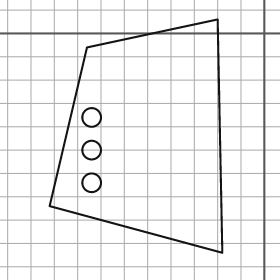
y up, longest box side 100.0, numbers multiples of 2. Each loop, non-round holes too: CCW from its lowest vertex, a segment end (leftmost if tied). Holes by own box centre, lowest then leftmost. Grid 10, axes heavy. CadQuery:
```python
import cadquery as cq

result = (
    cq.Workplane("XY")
    .moveTo(-18.0, -94.0)
    .lineTo(-20.0, 6.0)
    .lineTo(-76.0, -6.0)
    .lineTo(-92.0, -74.0)
    .close()
    .moveTo(-74.0, -64.0)
    .circle(4.0)
    .moveTo(-74.0, -50.0)
    .circle(4.0)
    .moveTo(-74.0, -36.0)
    .circle(4.0)
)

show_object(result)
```